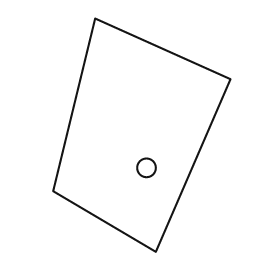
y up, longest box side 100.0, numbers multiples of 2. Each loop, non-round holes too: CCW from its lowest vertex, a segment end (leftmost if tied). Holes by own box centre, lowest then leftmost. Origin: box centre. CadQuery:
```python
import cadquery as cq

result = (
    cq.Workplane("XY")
    .moveTo(6.0, -50.0)
    .lineTo(38.0, 24.0)
    .lineTo(-20.0, 50.0)
    .lineTo(-38.0, -24.0)
    .close()
    .moveTo(2.0, -14.0)
    .circle(4.0)
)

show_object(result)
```